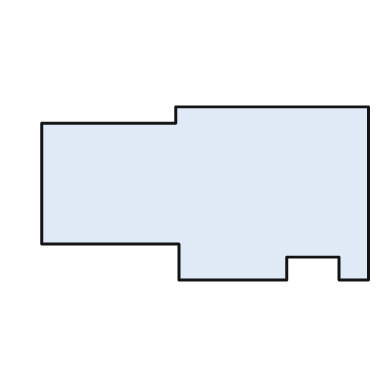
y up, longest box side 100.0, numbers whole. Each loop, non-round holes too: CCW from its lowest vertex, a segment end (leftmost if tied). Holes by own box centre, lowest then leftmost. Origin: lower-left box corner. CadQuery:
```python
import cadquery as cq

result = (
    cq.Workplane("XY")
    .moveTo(42.0, 0.0)
    .lineTo(75.0, 0.0)
    .lineTo(75.0, 7.0)
    .lineTo(91.0, 7.0)
    .lineTo(91.0, 0.0)
    .lineTo(100.0, 0.0)
    .lineTo(100.0, 53.0)
    .lineTo(41.0, 53.0)
    .lineTo(41.0, 48.0)
    .lineTo(0.0, 48.0)
    .lineTo(0.0, 11.0)
    .lineTo(42.0, 11.0)
    .close()
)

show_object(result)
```